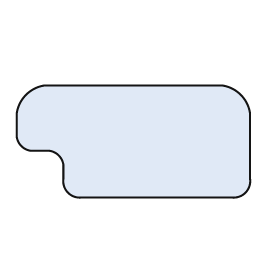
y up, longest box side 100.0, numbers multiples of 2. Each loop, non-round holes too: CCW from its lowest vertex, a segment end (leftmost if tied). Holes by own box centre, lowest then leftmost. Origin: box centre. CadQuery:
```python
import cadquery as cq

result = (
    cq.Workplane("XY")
    .moveTo(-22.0, -24.0)
    .lineTo(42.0, -24.0)
    .threePointArc((48.0, -22.0), (50.0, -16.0))
    .lineTo(50.0, 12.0)
    .threePointArc((46.0, 20.0), (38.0, 24.0))
    .lineTo(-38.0, 24.0)
    .threePointArc((-46.0, 20.0), (-50.0, 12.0))
    .lineTo(-50.0, 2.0)
    .threePointArc((-48.0, -2.0), (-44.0, -4.0))
    .lineTo(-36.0, -4.0)
    .threePointArc((-32.0, -6.0), (-30.0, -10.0))
    .lineTo(-30.0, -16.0)
    .threePointArc((-28.0, -22.0), (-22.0, -24.0))
    .close()
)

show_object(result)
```